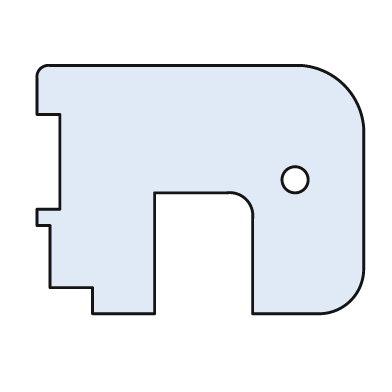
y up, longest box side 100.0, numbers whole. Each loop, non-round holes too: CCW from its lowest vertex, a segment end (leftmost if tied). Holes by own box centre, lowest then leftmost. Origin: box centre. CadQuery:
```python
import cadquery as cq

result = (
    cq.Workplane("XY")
    .moveTo(-33.0, -38.0)
    .lineTo(-14.0, -38.0)
    .lineTo(-14.0, -1.0)
    .lineTo(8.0, -1.0)
    .threePointArc((14.0, -3.0), (16.0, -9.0))
    .lineTo(16.0, -38.0)
    .lineTo(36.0, -38.0)
    .threePointArc((46.0, -34.0), (50.0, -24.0))
    .lineTo(50.0, 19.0)
    .threePointArc((44.0, 32.0), (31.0, 38.0))
    .lineTo(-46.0, 38.0)
    .threePointArc((-49.0, 37.0), (-50.0, 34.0))
    .lineTo(-50.0, 23.0)
    .lineTo(-43.0, 23.0)
    .lineTo(-43.0, -6.0)
    .lineTo(-50.0, -6.0)
    .lineTo(-50.0, -11.0)
    .lineTo(-46.0, -11.0)
    .lineTo(-46.0, -30.0)
    .lineTo(-33.0, -30.0)
    .close()
    .moveTo(29.0, 3.0)
    .circle(4.0)
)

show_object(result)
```